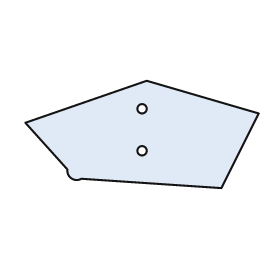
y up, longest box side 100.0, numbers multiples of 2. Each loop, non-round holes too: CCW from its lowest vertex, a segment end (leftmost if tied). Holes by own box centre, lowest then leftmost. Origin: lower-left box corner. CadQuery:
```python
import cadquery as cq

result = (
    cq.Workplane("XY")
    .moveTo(84.0, 0.0)
    .lineTo(100.0, 32.0)
    .lineTo(52.0, 46.0)
    .lineTo(0.0, 28.0)
    .lineTo(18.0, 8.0)
    .threePointArc((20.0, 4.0), (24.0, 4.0))
    .close()
    .moveTo(50.0, 16.0)
    .circle(2.0)
    .moveTo(50.0, 34.0)
    .circle(2.0)
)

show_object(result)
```